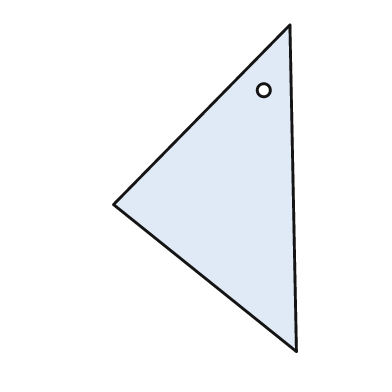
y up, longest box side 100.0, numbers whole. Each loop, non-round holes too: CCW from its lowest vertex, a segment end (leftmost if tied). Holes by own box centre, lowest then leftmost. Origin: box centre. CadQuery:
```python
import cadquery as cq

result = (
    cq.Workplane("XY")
    .moveTo(28.0, -50.0)
    .lineTo(26.0, 50.0)
    .lineTo(-28.0, -5.0)
    .close()
    .moveTo(18.0, 30.0)
    .circle(2.0)
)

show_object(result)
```